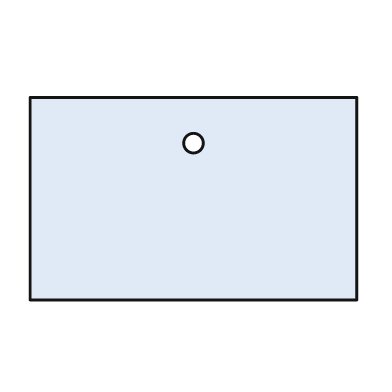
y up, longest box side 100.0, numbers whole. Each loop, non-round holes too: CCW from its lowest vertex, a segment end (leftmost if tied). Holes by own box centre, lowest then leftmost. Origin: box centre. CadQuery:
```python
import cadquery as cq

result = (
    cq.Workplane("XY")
    .moveTo(-50.0, -31.0)
    .lineTo(50.0, -31.0)
    .lineTo(50.0, 31.0)
    .lineTo(-50.0, 31.0)
    .close()
    .moveTo(0.0, 17.0)
    .circle(3.0)
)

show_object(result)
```